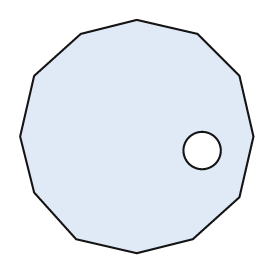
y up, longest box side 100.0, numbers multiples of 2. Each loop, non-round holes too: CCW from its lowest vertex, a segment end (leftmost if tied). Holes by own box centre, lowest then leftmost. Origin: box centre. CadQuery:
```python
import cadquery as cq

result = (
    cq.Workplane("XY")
    .moveTo(0.0, -50.0)
    .lineTo(24.0, -44.0)
    .lineTo(44.0, -26.0)
    .lineTo(50.0, 0.0)
    .lineTo(44.0, 26.0)
    .lineTo(26.0, 44.0)
    .lineTo(0.0, 50.0)
    .lineTo(-24.0, 44.0)
    .lineTo(-44.0, 26.0)
    .lineTo(-50.0, 0.0)
    .lineTo(-44.0, -24.0)
    .lineTo(-26.0, -44.0)
    .close()
    .moveTo(28.0, -6.0)
    .circle(8.0)
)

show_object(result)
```